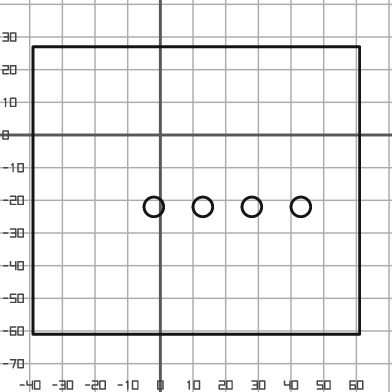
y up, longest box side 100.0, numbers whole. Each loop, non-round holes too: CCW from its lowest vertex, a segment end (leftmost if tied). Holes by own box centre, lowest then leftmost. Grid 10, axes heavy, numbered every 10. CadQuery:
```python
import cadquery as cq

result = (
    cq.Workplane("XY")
    .moveTo(-39.0, -61.0)
    .lineTo(61.0, -61.0)
    .lineTo(61.0, 27.0)
    .lineTo(-39.0, 27.0)
    .close()
    .moveTo(-2.0, -22.0)
    .circle(3.0)
    .moveTo(13.0, -22.0)
    .circle(3.0)
    .moveTo(28.0, -22.0)
    .circle(3.0)
    .moveTo(43.0, -22.0)
    .circle(3.0)
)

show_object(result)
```